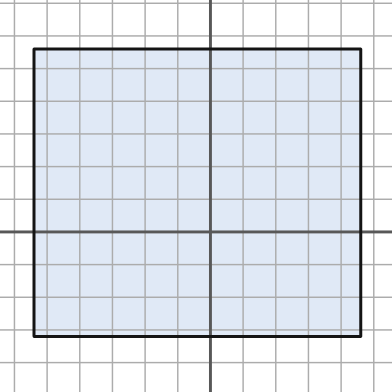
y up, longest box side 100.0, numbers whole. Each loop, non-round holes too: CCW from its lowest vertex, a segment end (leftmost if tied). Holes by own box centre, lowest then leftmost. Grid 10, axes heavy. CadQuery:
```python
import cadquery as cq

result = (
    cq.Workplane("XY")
    .moveTo(-54.0, -32.0)
    .lineTo(46.0, -32.0)
    .lineTo(46.0, 56.0)
    .lineTo(-54.0, 56.0)
    .close()
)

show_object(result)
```